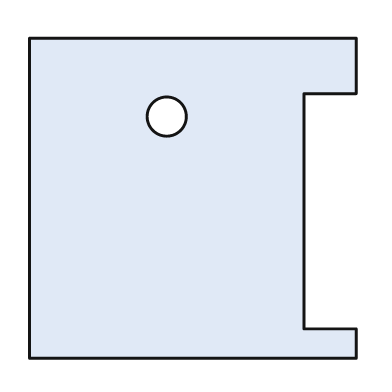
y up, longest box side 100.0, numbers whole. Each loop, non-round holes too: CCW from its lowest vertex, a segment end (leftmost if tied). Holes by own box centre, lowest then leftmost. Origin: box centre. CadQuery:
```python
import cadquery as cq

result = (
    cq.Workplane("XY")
    .moveTo(-50.0, -49.0)
    .lineTo(50.0, -49.0)
    .lineTo(50.0, -40.0)
    .lineTo(34.0, -40.0)
    .lineTo(34.0, 32.0)
    .lineTo(50.0, 32.0)
    .lineTo(50.0, 49.0)
    .lineTo(-50.0, 49.0)
    .close()
    .moveTo(-8.0, 25.0)
    .circle(6.0)
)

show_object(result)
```